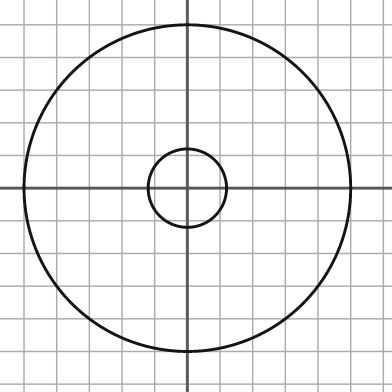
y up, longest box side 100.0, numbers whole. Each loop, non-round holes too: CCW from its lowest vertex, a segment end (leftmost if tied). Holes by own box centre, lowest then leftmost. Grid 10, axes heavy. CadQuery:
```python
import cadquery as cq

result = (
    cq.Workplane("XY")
    .moveTo(0.0, 0.0)
    .circle(50.0)
    .moveTo(0.0, 0.0)
    .circle(12.0)
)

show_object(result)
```